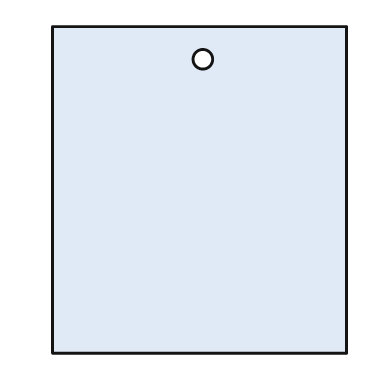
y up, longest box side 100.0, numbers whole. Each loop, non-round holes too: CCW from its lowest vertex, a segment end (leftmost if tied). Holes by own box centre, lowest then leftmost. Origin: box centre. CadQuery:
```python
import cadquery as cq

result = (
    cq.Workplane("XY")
    .moveTo(-45.0, -50.0)
    .lineTo(45.0, -50.0)
    .lineTo(45.0, 50.0)
    .lineTo(-45.0, 50.0)
    .close()
    .moveTo(1.0, 40.0)
    .circle(3.0)
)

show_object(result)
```